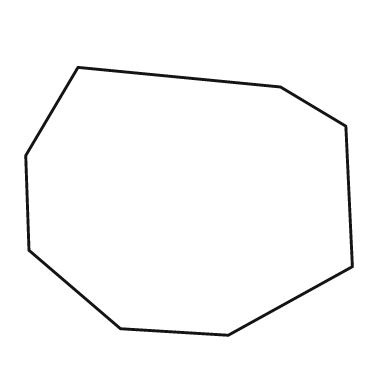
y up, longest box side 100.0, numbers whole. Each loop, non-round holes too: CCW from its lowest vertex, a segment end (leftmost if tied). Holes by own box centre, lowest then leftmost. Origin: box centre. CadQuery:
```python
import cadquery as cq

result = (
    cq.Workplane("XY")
    .moveTo(12.0, -41.0)
    .lineTo(50.0, -20.0)
    .lineTo(48.0, 23.0)
    .lineTo(28.0, 35.0)
    .lineTo(-34.0, 41.0)
    .lineTo(-50.0, 14.0)
    .lineTo(-49.0, -15.0)
    .lineTo(-21.0, -39.0)
    .close()
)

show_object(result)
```